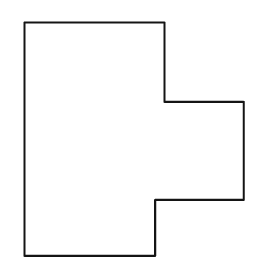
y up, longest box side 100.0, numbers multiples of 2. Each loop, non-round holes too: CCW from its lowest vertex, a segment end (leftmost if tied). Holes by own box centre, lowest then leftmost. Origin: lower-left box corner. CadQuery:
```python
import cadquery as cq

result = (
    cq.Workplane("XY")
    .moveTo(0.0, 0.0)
    .lineTo(56.0, 0.0)
    .lineTo(56.0, 24.0)
    .lineTo(94.0, 24.0)
    .lineTo(94.0, 66.0)
    .lineTo(60.0, 66.0)
    .lineTo(60.0, 100.0)
    .lineTo(0.0, 100.0)
    .close()
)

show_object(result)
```